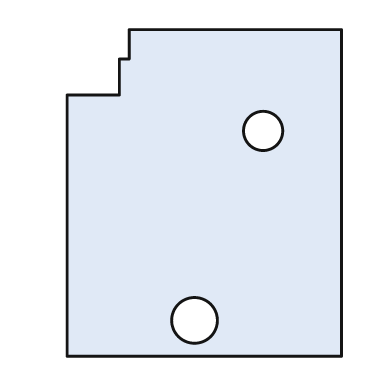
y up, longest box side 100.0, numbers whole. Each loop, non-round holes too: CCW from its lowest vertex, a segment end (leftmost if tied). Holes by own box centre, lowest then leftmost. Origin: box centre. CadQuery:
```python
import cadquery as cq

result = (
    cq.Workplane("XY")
    .moveTo(-42.0, -50.0)
    .lineTo(42.0, -50.0)
    .lineTo(42.0, 50.0)
    .lineTo(-23.0, 50.0)
    .lineTo(-23.0, 41.0)
    .lineTo(-26.0, 41.0)
    .lineTo(-26.0, 30.0)
    .lineTo(-42.0, 30.0)
    .close()
    .moveTo(-3.0, -39.0)
    .circle(7.0)
    .moveTo(18.0, 19.0)
    .circle(6.0)
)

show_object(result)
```